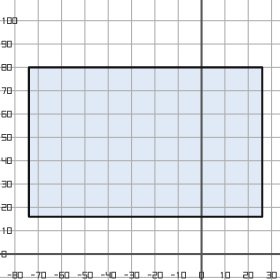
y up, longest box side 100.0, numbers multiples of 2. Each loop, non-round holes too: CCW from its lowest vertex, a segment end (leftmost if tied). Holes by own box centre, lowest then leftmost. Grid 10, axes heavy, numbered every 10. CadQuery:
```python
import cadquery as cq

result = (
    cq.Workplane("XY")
    .moveTo(-74.0, 16.0)
    .lineTo(26.0, 16.0)
    .lineTo(26.0, 80.0)
    .lineTo(-74.0, 80.0)
    .close()
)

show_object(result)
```